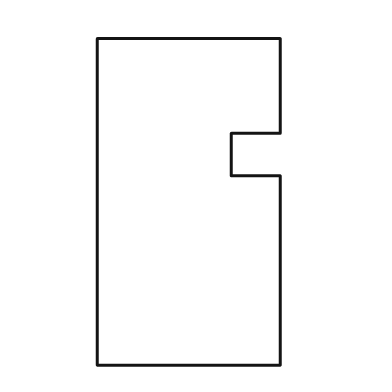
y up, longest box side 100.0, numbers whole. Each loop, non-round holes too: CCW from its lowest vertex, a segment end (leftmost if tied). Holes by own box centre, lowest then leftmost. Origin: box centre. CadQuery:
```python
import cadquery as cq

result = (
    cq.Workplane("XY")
    .moveTo(-28.0, -50.0)
    .lineTo(28.0, -50.0)
    .lineTo(28.0, 8.0)
    .lineTo(13.0, 8.0)
    .lineTo(13.0, 21.0)
    .lineTo(28.0, 21.0)
    .lineTo(28.0, 50.0)
    .lineTo(-28.0, 50.0)
    .close()
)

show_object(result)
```